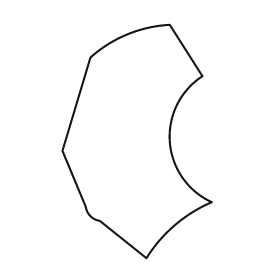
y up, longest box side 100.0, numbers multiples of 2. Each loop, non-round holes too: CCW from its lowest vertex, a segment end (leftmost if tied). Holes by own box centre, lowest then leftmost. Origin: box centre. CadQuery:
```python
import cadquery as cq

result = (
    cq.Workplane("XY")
    .moveTo(4.0, -50.0)
    .threePointArc((16.0, -36.0), (32.0, -26.0))
    .threePointArc((14.0, 0.0), (28.0, 28.0))
    .lineTo(14.0, 50.0)
    .threePointArc((-4.0, 46.0), (-20.0, 36.0))
    .lineTo(-32.0, -4.0)
    .lineTo(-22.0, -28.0)
    .threePointArc((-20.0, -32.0), (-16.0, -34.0))
    .close()
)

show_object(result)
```